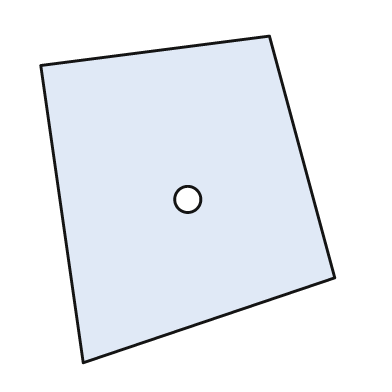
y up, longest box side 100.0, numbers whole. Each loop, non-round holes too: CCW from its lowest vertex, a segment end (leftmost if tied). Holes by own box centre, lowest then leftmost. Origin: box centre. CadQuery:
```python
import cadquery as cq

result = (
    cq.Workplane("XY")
    .moveTo(-32.0, -50.0)
    .lineTo(45.0, -24.0)
    .lineTo(25.0, 50.0)
    .lineTo(-45.0, 41.0)
    .close()
    .moveTo(0.0, 0.0)
    .circle(4.0)
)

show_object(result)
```